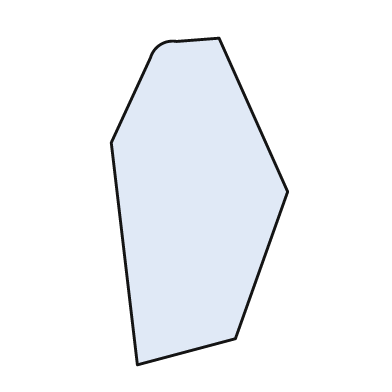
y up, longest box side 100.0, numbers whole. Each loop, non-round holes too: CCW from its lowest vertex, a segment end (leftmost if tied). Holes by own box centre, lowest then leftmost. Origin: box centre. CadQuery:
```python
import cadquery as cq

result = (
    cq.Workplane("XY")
    .moveTo(-19.0, -50.0)
    .lineTo(11.0, -42.0)
    .lineTo(27.0, 3.0)
    .lineTo(6.0, 50.0)
    .lineTo(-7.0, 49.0)
    .threePointArc((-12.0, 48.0), (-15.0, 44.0))
    .lineTo(-27.0, 18.0)
    .close()
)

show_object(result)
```